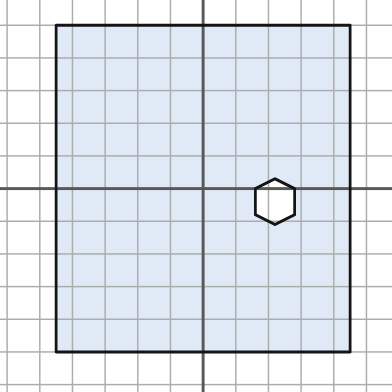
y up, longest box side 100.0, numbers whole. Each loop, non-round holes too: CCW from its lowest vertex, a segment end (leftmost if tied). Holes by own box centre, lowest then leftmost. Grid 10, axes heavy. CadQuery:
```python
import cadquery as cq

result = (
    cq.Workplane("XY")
    .moveTo(-45.0, -50.0)
    .lineTo(45.0, -50.0)
    .lineTo(45.0, 50.0)
    .lineTo(-45.0, 50.0)
    .close()
    .moveTo(22.0, -11.0)
    .lineTo(28.0, -8.0)
    .lineTo(28.0, 0.0)
    .lineTo(22.0, 3.0)
    .lineTo(16.0, 0.0)
    .lineTo(16.0, -8.0)
    .close()
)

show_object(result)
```